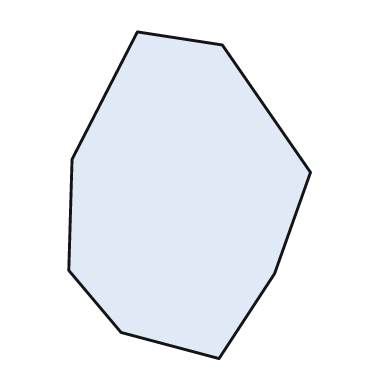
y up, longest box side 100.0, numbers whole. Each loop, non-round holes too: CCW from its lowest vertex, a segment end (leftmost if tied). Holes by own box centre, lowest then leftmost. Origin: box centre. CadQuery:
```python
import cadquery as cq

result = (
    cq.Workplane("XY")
    .moveTo(9.0, -50.0)
    .lineTo(26.0, -24.0)
    .lineTo(37.0, 7.0)
    .lineTo(10.0, 46.0)
    .lineTo(-16.0, 50.0)
    .lineTo(-36.0, 11.0)
    .lineTo(-37.0, -23.0)
    .lineTo(-21.0, -42.0)
    .close()
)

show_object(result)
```